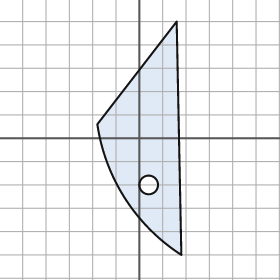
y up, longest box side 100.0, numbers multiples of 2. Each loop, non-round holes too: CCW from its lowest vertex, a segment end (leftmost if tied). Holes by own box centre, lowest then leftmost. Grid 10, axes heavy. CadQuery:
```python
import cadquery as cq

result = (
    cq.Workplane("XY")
    .moveTo(18.0, -50.0)
    .lineTo(16.0, 50.0)
    .lineTo(-18.0, 6.0)
    .threePointArc((-6.0, -26.0), (18.0, -50.0))
    .close()
    .moveTo(4.0, -20.0)
    .circle(4.0)
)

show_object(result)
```